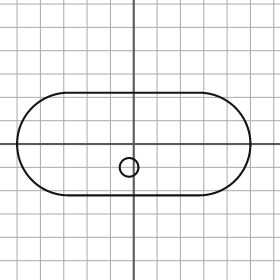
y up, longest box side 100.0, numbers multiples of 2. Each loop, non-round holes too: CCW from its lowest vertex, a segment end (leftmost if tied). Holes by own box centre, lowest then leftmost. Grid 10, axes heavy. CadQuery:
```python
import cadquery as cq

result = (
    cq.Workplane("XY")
    .moveTo(-28.0, -22.0)
    .lineTo(28.0, -22.0)
    .threePointArc((50.0, 0.0), (28.0, 22.0))
    .lineTo(-28.0, 22.0)
    .threePointArc((-50.0, 0.0), (-28.0, -22.0))
    .close()
    .moveTo(-2.0, -10.0)
    .circle(4.0)
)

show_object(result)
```